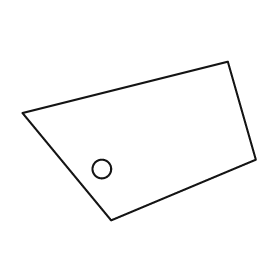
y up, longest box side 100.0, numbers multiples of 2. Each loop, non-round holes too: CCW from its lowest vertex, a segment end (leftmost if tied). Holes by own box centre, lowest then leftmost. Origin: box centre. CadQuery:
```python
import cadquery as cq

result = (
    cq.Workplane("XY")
    .moveTo(-12.0, -34.0)
    .lineTo(50.0, -8.0)
    .lineTo(38.0, 34.0)
    .lineTo(-50.0, 12.0)
    .close()
    .moveTo(-16.0, -12.0)
    .circle(4.0)
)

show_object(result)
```